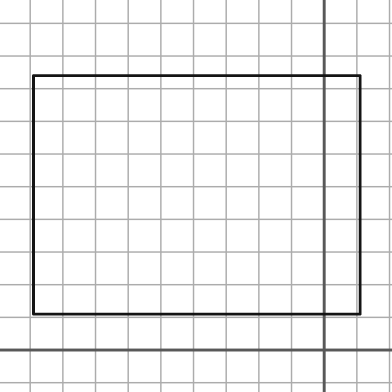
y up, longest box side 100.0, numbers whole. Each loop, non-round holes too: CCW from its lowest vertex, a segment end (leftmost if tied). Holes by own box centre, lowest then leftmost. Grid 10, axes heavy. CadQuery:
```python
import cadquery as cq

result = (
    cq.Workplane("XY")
    .moveTo(-89.0, 11.0)
    .lineTo(11.0, 11.0)
    .lineTo(11.0, 84.0)
    .lineTo(-89.0, 84.0)
    .close()
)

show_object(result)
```